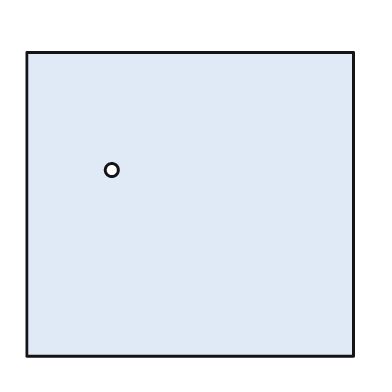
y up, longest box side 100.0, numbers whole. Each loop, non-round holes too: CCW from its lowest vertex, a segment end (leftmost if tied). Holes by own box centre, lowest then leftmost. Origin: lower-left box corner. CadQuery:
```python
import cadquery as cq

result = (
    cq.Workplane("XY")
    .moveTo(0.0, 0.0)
    .lineTo(100.0, 0.0)
    .lineTo(100.0, 93.0)
    .lineTo(0.0, 93.0)
    .close()
    .moveTo(26.0, 57.0)
    .circle(2.0)
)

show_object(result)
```